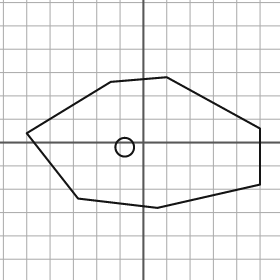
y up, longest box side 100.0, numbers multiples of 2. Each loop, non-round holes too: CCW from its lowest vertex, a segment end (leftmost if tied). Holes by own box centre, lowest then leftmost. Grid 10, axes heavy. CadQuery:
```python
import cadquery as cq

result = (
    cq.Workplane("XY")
    .moveTo(6.0, -28.0)
    .lineTo(50.0, -18.0)
    .lineTo(50.0, 6.0)
    .lineTo(10.0, 28.0)
    .lineTo(-14.0, 26.0)
    .lineTo(-50.0, 4.0)
    .lineTo(-28.0, -24.0)
    .close()
    .moveTo(-8.0, -2.0)
    .circle(4.0)
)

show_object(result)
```